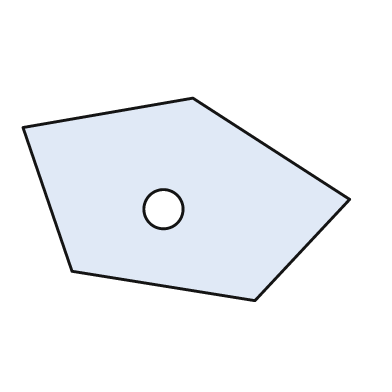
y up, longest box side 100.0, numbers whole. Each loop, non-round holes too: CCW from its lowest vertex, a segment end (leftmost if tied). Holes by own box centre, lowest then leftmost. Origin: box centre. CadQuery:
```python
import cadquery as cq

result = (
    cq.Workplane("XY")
    .moveTo(21.0, -31.0)
    .lineTo(50.0, 0.0)
    .lineTo(2.0, 31.0)
    .lineTo(-50.0, 22.0)
    .lineTo(-35.0, -22.0)
    .close()
    .moveTo(-7.0, -3.0)
    .circle(6.0)
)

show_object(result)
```